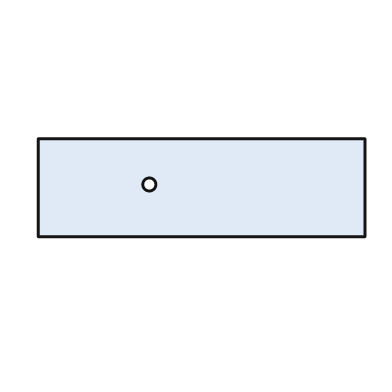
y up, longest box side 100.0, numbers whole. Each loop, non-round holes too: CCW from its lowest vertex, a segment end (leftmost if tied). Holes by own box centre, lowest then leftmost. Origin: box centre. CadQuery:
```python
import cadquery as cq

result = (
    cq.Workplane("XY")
    .moveTo(-50.0, -15.0)
    .lineTo(50.0, -15.0)
    .lineTo(50.0, 15.0)
    .lineTo(-50.0, 15.0)
    .close()
    .moveTo(-16.0, 1.0)
    .circle(2.0)
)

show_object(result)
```